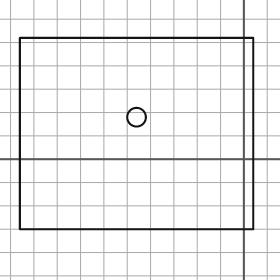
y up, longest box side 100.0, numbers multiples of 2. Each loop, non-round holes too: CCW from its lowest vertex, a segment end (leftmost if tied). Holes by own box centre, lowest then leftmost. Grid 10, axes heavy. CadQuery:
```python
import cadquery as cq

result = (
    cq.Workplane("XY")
    .moveTo(-96.0, -30.0)
    .lineTo(4.0, -30.0)
    .lineTo(4.0, 52.0)
    .lineTo(-96.0, 52.0)
    .close()
    .moveTo(-46.0, 18.0)
    .circle(4.0)
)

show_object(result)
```